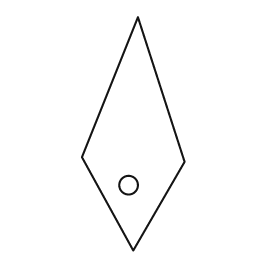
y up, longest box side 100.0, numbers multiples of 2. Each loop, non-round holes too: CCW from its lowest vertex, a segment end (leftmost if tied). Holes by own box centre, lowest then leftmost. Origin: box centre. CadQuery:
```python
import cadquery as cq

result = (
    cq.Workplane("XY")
    .moveTo(0.0, -50.0)
    .lineTo(22.0, -12.0)
    .lineTo(2.0, 50.0)
    .lineTo(-22.0, -10.0)
    .close()
    .moveTo(-2.0, -22.0)
    .circle(4.0)
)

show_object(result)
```